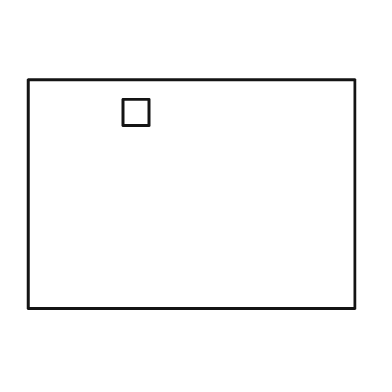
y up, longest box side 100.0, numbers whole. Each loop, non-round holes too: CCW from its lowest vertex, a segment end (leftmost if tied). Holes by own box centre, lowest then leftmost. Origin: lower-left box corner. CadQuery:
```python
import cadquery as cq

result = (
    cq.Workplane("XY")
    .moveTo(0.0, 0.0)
    .lineTo(100.0, 0.0)
    .lineTo(100.0, 70.0)
    .lineTo(0.0, 70.0)
    .close()
    .moveTo(29.0, 56.0)
    .lineTo(37.0, 56.0)
    .lineTo(37.0, 64.0)
    .lineTo(29.0, 64.0)
    .close()
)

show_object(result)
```